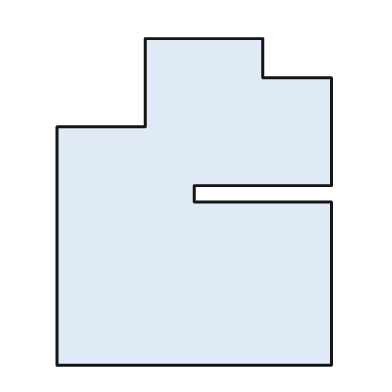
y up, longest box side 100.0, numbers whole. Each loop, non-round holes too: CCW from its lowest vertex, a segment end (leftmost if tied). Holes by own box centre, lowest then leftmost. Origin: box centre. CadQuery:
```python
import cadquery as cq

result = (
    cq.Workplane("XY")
    .moveTo(-42.0, -50.0)
    .lineTo(42.0, -50.0)
    .lineTo(42.0, 0.0)
    .lineTo(0.0, 0.0)
    .lineTo(0.0, 5.0)
    .lineTo(42.0, 5.0)
    .lineTo(42.0, 38.0)
    .lineTo(21.0, 38.0)
    .lineTo(21.0, 50.0)
    .lineTo(-15.0, 50.0)
    .lineTo(-15.0, 23.0)
    .lineTo(-42.0, 23.0)
    .close()
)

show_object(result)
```